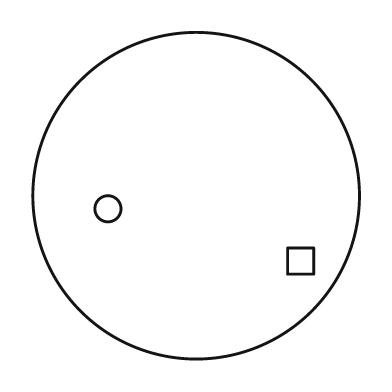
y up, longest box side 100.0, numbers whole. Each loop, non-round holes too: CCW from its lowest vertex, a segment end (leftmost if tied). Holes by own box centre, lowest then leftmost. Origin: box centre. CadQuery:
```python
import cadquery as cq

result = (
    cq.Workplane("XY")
    .moveTo(0.0, 0.0)
    .circle(50.0)
    .moveTo(28.0, -24.0)
    .lineTo(36.0, -24.0)
    .lineTo(36.0, -16.0)
    .lineTo(28.0, -16.0)
    .close()
    .moveTo(-27.0, -4.0)
    .circle(4.0)
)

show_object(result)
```